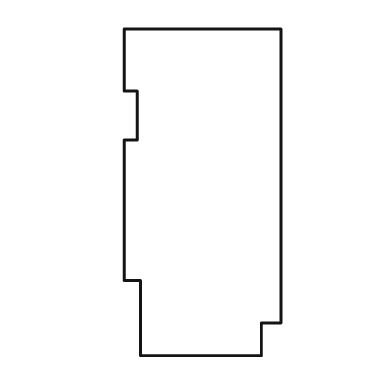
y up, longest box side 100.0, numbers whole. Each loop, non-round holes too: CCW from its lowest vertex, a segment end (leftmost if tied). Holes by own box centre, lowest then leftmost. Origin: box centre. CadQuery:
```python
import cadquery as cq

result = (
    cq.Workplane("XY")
    .moveTo(-19.0, -50.0)
    .lineTo(18.0, -50.0)
    .lineTo(18.0, -40.0)
    .lineTo(24.0, -40.0)
    .lineTo(24.0, 50.0)
    .lineTo(-24.0, 50.0)
    .lineTo(-24.0, 31.0)
    .lineTo(-20.0, 31.0)
    .lineTo(-20.0, 16.0)
    .lineTo(-24.0, 16.0)
    .lineTo(-24.0, -27.0)
    .lineTo(-19.0, -27.0)
    .close()
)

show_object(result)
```